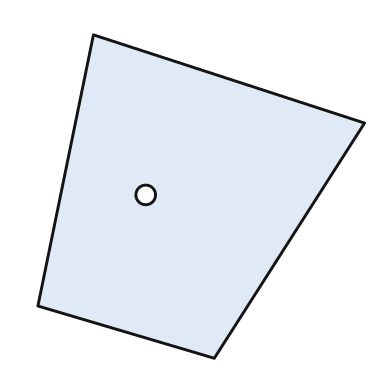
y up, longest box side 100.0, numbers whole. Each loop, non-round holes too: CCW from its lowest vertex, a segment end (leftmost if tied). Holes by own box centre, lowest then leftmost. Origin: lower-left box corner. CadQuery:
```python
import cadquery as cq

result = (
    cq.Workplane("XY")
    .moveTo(54.0, 0.0)
    .lineTo(100.0, 72.0)
    .lineTo(17.0, 99.0)
    .lineTo(0.0, 16.0)
    .close()
    .moveTo(33.0, 50.0)
    .circle(3.0)
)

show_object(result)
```